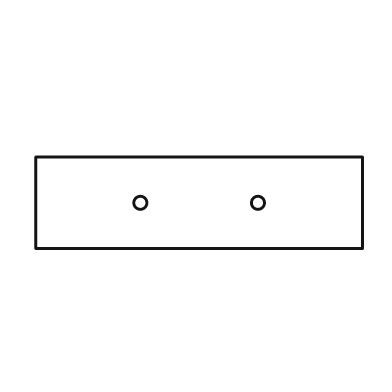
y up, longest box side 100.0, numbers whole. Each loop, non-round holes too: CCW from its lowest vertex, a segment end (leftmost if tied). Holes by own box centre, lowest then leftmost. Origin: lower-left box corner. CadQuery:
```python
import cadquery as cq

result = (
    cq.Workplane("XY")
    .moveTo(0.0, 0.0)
    .lineTo(100.0, 0.0)
    .lineTo(100.0, 28.0)
    .lineTo(0.0, 28.0)
    .close()
    .moveTo(32.0, 14.0)
    .circle(2.0)
    .moveTo(68.0, 14.0)
    .circle(2.0)
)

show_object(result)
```